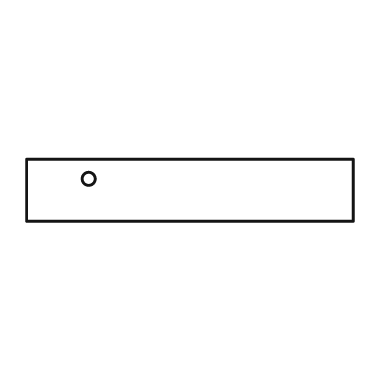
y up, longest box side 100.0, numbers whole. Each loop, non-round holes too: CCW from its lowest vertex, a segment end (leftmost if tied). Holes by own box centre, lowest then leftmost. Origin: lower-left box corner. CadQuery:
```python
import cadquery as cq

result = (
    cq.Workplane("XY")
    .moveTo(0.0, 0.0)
    .lineTo(100.0, 0.0)
    .lineTo(100.0, 19.0)
    .lineTo(0.0, 19.0)
    .close()
    .moveTo(19.0, 13.0)
    .circle(2.0)
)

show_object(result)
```